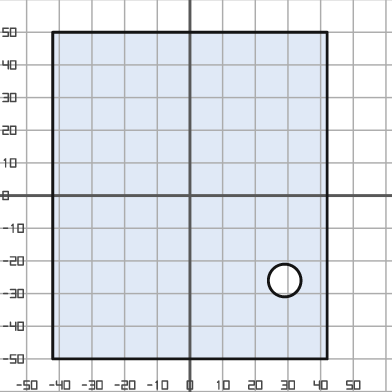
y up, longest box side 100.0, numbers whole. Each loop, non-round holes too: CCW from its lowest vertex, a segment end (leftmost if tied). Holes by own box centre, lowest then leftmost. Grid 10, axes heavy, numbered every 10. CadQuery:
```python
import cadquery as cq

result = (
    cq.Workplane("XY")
    .moveTo(-42.0, -50.0)
    .lineTo(42.0, -50.0)
    .lineTo(42.0, 50.0)
    .lineTo(-42.0, 50.0)
    .close()
    .moveTo(29.0, -26.0)
    .circle(5.0)
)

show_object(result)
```